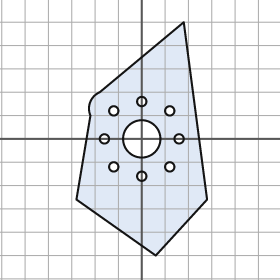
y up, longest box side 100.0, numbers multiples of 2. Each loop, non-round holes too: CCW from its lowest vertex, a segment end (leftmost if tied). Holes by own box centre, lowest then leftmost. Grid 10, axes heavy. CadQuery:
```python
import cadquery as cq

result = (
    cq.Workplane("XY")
    .moveTo(6.0, -50.0)
    .lineTo(28.0, -26.0)
    .lineTo(18.0, 50.0)
    .lineTo(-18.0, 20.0)
    .threePointArc((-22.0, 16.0), (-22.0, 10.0))
    .lineTo(-28.0, -26.0)
    .close()
    .moveTo(0.0, -16.0)
    .circle(2.0)
    .moveTo(-12.0, -12.0)
    .circle(2.0)
    .moveTo(12.0, -12.0)
    .circle(2.0)
    .moveTo(-16.0, 0.0)
    .circle(2.0)
    .moveTo(0.0, 0.0)
    .circle(8.0)
    .moveTo(16.0, 0.0)
    .circle(2.0)
    .moveTo(-12.0, 12.0)
    .circle(2.0)
    .moveTo(12.0, 12.0)
    .circle(2.0)
    .moveTo(0.0, 16.0)
    .circle(2.0)
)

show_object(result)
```